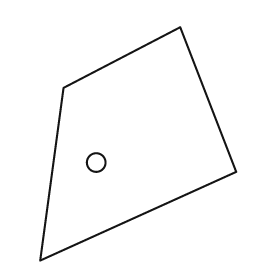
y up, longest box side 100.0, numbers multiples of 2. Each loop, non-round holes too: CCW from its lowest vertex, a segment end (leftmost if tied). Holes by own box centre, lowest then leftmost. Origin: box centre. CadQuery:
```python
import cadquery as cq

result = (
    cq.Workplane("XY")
    .moveTo(-42.0, -50.0)
    .lineTo(42.0, -12.0)
    .lineTo(18.0, 50.0)
    .lineTo(-32.0, 24.0)
    .close()
    .moveTo(-18.0, -8.0)
    .circle(4.0)
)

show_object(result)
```